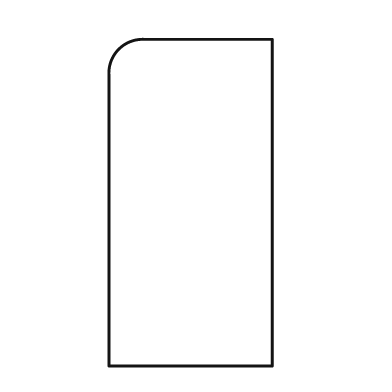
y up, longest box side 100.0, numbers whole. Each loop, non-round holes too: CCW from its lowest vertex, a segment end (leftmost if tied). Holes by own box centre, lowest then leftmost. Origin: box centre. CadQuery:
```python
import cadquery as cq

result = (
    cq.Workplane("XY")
    .moveTo(-25.0, -50.0)
    .lineTo(25.0, -50.0)
    .lineTo(25.0, 50.0)
    .lineTo(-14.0, 50.0)
    .threePointArc((-22.0, 47.0), (-25.0, 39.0))
    .close()
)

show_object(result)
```